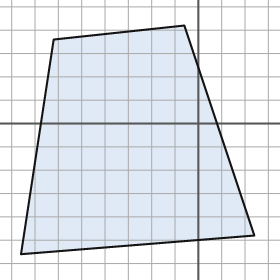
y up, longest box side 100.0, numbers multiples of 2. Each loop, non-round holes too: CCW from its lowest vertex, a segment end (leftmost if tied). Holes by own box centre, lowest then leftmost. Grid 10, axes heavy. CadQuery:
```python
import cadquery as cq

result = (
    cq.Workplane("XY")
    .moveTo(-76.0, -56.0)
    .lineTo(24.0, -48.0)
    .lineTo(-6.0, 42.0)
    .lineTo(-62.0, 36.0)
    .close()
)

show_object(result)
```